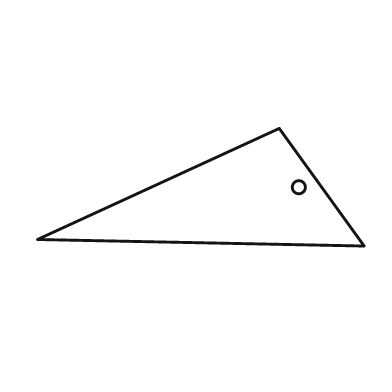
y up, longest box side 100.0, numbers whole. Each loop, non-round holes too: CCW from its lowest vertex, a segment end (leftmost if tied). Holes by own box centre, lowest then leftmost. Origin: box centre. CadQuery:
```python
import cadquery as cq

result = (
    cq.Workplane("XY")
    .moveTo(50.0, -18.0)
    .lineTo(24.0, 18.0)
    .lineTo(-50.0, -16.0)
    .close()
    .moveTo(30.0, 0.0)
    .circle(2.0)
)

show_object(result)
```